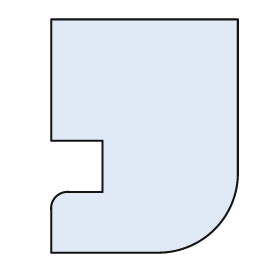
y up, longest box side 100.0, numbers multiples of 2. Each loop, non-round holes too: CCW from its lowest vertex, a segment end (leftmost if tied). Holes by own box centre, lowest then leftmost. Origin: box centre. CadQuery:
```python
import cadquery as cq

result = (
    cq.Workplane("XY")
    .moveTo(-40.0, -50.0)
    .lineTo(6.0, -50.0)
    .threePointArc((30.0, -40.0), (40.0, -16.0))
    .lineTo(40.0, 50.0)
    .lineTo(-40.0, 50.0)
    .lineTo(-40.0, -2.0)
    .lineTo(-18.0, -2.0)
    .lineTo(-18.0, -24.0)
    .lineTo(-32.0, -24.0)
    .threePointArc((-38.0, -26.0), (-40.0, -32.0))
    .close()
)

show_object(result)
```